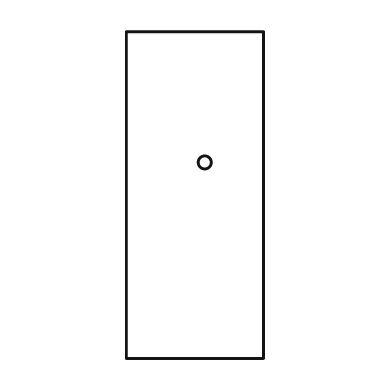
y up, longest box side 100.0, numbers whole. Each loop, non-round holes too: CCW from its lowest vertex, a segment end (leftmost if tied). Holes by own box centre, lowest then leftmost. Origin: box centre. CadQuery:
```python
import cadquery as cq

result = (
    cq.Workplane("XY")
    .moveTo(-21.0, -50.0)
    .lineTo(21.0, -50.0)
    .lineTo(21.0, 50.0)
    .lineTo(-21.0, 50.0)
    .close()
    .moveTo(3.0, 10.0)
    .circle(2.0)
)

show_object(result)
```